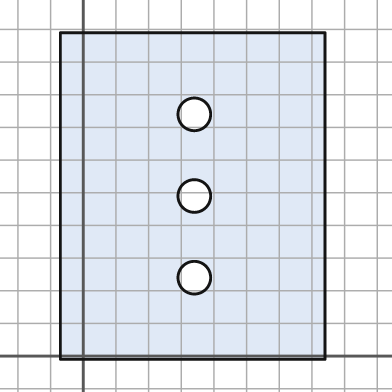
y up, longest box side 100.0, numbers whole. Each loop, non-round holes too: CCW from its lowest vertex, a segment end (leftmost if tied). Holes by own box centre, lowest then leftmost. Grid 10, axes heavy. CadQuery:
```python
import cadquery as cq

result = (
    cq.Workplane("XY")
    .moveTo(-7.0, -1.0)
    .lineTo(74.0, -1.0)
    .lineTo(74.0, 99.0)
    .lineTo(-7.0, 99.0)
    .close()
    .moveTo(34.0, 24.0)
    .circle(5.0)
    .moveTo(34.0, 49.0)
    .circle(5.0)
    .moveTo(34.0, 74.0)
    .circle(5.0)
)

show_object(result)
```